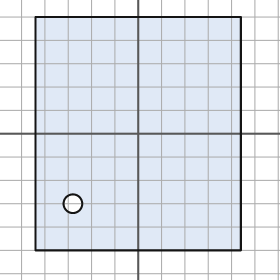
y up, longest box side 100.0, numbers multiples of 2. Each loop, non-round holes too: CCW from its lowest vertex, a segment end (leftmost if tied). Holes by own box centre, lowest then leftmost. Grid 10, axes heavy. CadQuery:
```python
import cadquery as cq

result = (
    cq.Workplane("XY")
    .moveTo(-44.0, -50.0)
    .lineTo(44.0, -50.0)
    .lineTo(44.0, 50.0)
    .lineTo(-44.0, 50.0)
    .close()
    .moveTo(-28.0, -30.0)
    .circle(4.0)
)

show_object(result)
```